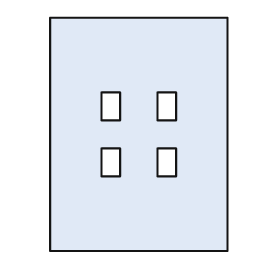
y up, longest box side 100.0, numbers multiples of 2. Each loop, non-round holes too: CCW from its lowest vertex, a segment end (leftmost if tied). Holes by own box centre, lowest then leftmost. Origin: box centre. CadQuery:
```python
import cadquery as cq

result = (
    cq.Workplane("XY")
    .moveTo(-38.0, -50.0)
    .lineTo(38.0, -50.0)
    .lineTo(38.0, 50.0)
    .lineTo(-38.0, 50.0)
    .close()
    .moveTo(-16.0, -18.0)
    .lineTo(-8.0, -18.0)
    .lineTo(-8.0, -6.0)
    .lineTo(-16.0, -6.0)
    .close()
    .moveTo(8.0, -18.0)
    .lineTo(16.0, -18.0)
    .lineTo(16.0, -6.0)
    .lineTo(8.0, -6.0)
    .close()
    .moveTo(-16.0, 6.0)
    .lineTo(-8.0, 6.0)
    .lineTo(-8.0, 18.0)
    .lineTo(-16.0, 18.0)
    .close()
    .moveTo(8.0, 6.0)
    .lineTo(16.0, 6.0)
    .lineTo(16.0, 18.0)
    .lineTo(8.0, 18.0)
    .close()
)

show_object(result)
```